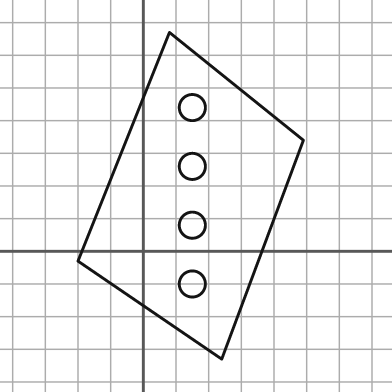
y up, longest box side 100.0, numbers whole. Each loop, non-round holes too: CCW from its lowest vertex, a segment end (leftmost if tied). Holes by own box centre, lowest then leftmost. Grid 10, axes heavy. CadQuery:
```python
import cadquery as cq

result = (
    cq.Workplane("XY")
    .moveTo(24.0, -33.0)
    .lineTo(49.0, 34.0)
    .lineTo(8.0, 67.0)
    .lineTo(-20.0, -3.0)
    .close()
    .moveTo(15.0, -10.0)
    .circle(4.0)
    .moveTo(15.0, 8.0)
    .circle(4.0)
    .moveTo(15.0, 26.0)
    .circle(4.0)
    .moveTo(15.0, 44.0)
    .circle(4.0)
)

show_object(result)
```